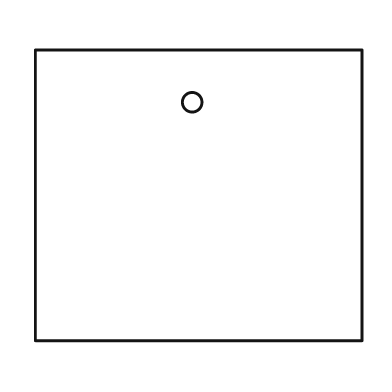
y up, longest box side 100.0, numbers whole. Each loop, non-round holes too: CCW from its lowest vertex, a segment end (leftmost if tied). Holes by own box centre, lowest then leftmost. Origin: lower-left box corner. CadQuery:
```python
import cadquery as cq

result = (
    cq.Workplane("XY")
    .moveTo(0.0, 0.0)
    .lineTo(100.0, 0.0)
    .lineTo(100.0, 89.0)
    .lineTo(0.0, 89.0)
    .close()
    .moveTo(48.0, 73.0)
    .circle(3.0)
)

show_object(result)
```